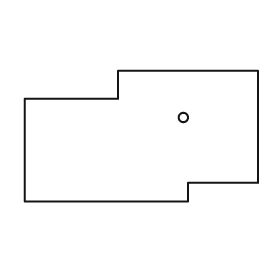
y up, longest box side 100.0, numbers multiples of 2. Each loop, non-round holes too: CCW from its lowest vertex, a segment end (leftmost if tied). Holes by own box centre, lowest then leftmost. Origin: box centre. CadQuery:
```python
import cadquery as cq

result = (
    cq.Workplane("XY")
    .moveTo(-50.0, -28.0)
    .lineTo(20.0, -28.0)
    .lineTo(20.0, -20.0)
    .lineTo(50.0, -20.0)
    .lineTo(50.0, 28.0)
    .lineTo(-10.0, 28.0)
    .lineTo(-10.0, 16.0)
    .lineTo(-50.0, 16.0)
    .close()
    .moveTo(18.0, 8.0)
    .circle(2.0)
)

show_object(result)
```